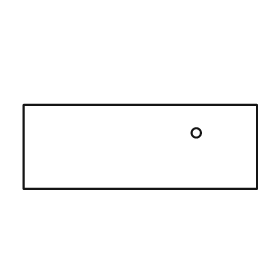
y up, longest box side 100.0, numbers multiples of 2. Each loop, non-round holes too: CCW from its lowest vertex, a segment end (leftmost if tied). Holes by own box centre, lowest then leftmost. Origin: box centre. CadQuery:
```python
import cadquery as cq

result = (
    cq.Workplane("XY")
    .moveTo(-50.0, -18.0)
    .lineTo(50.0, -18.0)
    .lineTo(50.0, 18.0)
    .lineTo(-50.0, 18.0)
    .close()
    .moveTo(24.0, 6.0)
    .circle(2.0)
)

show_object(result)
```